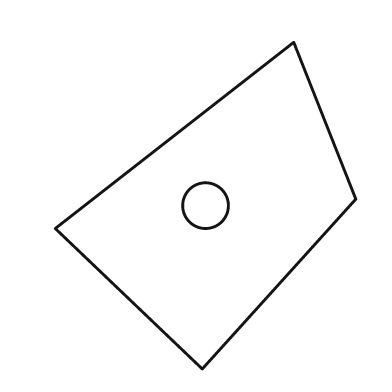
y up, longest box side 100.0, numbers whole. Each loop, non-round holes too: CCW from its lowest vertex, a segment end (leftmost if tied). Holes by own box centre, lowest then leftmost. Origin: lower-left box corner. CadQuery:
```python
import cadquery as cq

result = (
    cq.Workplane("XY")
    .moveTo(45.0, 0.0)
    .lineTo(92.0, 52.0)
    .lineTo(73.0, 100.0)
    .lineTo(0.0, 43.0)
    .close()
    .moveTo(46.0, 50.0)
    .circle(7.0)
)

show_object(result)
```